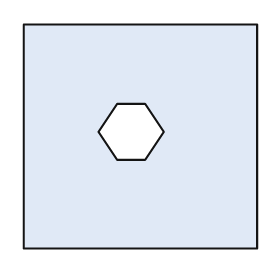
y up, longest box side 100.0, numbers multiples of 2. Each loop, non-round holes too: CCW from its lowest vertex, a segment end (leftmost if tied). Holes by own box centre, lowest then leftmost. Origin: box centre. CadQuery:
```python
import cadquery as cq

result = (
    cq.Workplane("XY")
    .moveTo(-50.0, -48.0)
    .lineTo(50.0, -48.0)
    .lineTo(50.0, 48.0)
    .lineTo(-50.0, 48.0)
    .close()
    .moveTo(-10.0, -10.0)
    .lineTo(2.0, -10.0)
    .lineTo(10.0, 2.0)
    .lineTo(2.0, 14.0)
    .lineTo(-10.0, 14.0)
    .lineTo(-18.0, 2.0)
    .close()
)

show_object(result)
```